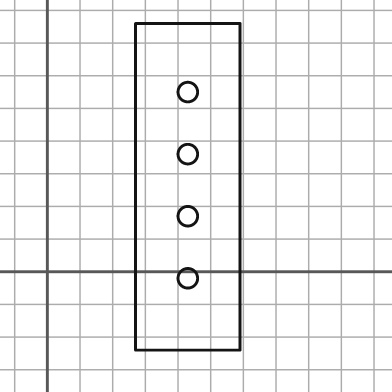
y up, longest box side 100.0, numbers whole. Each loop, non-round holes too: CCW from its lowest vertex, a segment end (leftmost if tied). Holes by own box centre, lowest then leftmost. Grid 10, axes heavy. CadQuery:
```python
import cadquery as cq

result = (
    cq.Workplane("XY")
    .moveTo(27.0, -24.0)
    .lineTo(59.0, -24.0)
    .lineTo(59.0, 76.0)
    .lineTo(27.0, 76.0)
    .close()
    .moveTo(43.0, -2.0)
    .circle(3.0)
    .moveTo(43.0, 17.0)
    .circle(3.0)
    .moveTo(43.0, 36.0)
    .circle(3.0)
    .moveTo(43.0, 55.0)
    .circle(3.0)
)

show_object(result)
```